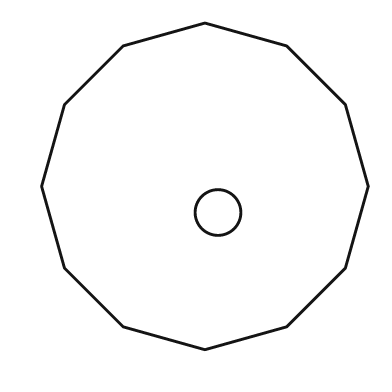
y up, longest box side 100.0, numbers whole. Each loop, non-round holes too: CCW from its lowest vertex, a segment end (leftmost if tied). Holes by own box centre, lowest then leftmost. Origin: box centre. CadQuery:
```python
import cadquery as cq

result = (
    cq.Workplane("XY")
    .moveTo(0.0, -50.0)
    .lineTo(25.0, -43.0)
    .lineTo(43.0, -25.0)
    .lineTo(50.0, 0.0)
    .lineTo(43.0, 25.0)
    .lineTo(25.0, 43.0)
    .lineTo(0.0, 50.0)
    .lineTo(-25.0, 43.0)
    .lineTo(-43.0, 25.0)
    .lineTo(-50.0, 0.0)
    .lineTo(-43.0, -25.0)
    .lineTo(-25.0, -43.0)
    .close()
    .moveTo(4.0, -8.0)
    .circle(7.0)
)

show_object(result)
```